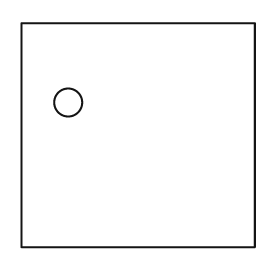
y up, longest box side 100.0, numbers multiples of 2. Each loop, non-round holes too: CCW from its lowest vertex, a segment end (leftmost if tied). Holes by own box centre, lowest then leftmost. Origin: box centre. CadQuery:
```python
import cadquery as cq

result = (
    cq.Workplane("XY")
    .moveTo(-50.0, -48.0)
    .lineTo(50.0, -48.0)
    .lineTo(50.0, 48.0)
    .lineTo(-50.0, 48.0)
    .close()
    .moveTo(-30.0, 14.0)
    .circle(6.0)
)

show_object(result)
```